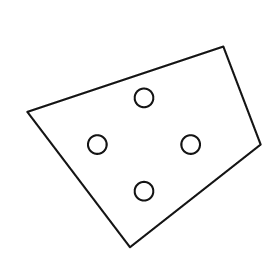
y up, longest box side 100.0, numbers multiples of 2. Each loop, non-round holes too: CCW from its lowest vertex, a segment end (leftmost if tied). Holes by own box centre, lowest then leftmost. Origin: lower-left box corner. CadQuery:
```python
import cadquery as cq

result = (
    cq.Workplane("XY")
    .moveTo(44.0, 0.0)
    .lineTo(100.0, 44.0)
    .lineTo(84.0, 86.0)
    .lineTo(0.0, 58.0)
    .close()
    .moveTo(50.0, 24.0)
    .circle(4.0)
    .moveTo(30.0, 44.0)
    .circle(4.0)
    .moveTo(70.0, 44.0)
    .circle(4.0)
    .moveTo(50.0, 64.0)
    .circle(4.0)
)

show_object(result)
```